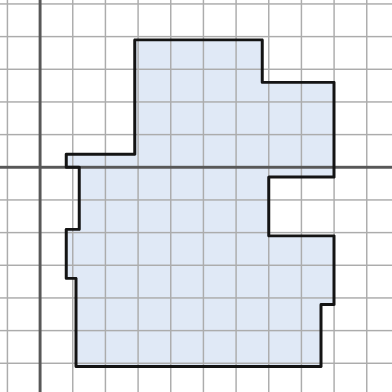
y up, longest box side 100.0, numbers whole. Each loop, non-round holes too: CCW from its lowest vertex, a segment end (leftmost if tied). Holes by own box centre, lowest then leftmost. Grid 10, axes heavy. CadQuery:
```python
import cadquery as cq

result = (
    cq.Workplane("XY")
    .moveTo(11.0, -61.0)
    .lineTo(86.0, -61.0)
    .lineTo(86.0, -42.0)
    .lineTo(90.0, -42.0)
    .lineTo(90.0, -21.0)
    .lineTo(70.0, -21.0)
    .lineTo(70.0, -3.0)
    .lineTo(90.0, -3.0)
    .lineTo(90.0, 26.0)
    .lineTo(68.0, 26.0)
    .lineTo(68.0, 39.0)
    .lineTo(29.0, 39.0)
    .lineTo(29.0, 4.0)
    .lineTo(8.0, 4.0)
    .lineTo(8.0, 0.0)
    .lineTo(12.0, 0.0)
    .lineTo(12.0, -19.0)
    .lineTo(8.0, -19.0)
    .lineTo(8.0, -34.0)
    .lineTo(11.0, -34.0)
    .close()
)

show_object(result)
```